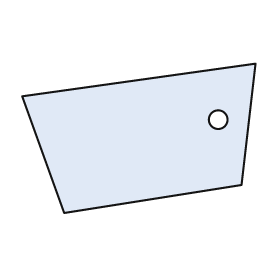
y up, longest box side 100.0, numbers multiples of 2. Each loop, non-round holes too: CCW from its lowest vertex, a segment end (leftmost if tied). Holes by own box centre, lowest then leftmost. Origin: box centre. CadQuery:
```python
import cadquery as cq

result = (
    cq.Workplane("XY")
    .moveTo(-32.0, -32.0)
    .lineTo(44.0, -20.0)
    .lineTo(50.0, 32.0)
    .lineTo(-50.0, 18.0)
    .close()
    .moveTo(34.0, 8.0)
    .circle(4.0)
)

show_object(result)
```